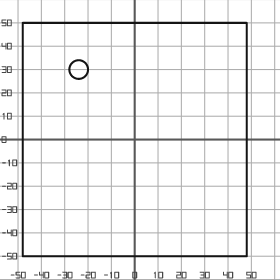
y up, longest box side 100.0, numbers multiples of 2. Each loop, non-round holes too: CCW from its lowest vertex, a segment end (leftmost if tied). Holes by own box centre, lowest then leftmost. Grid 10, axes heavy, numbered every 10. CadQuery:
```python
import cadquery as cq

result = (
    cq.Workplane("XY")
    .moveTo(-48.0, -50.0)
    .lineTo(48.0, -50.0)
    .lineTo(48.0, 50.0)
    .lineTo(-48.0, 50.0)
    .close()
    .moveTo(-24.0, 30.0)
    .circle(4.0)
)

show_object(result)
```